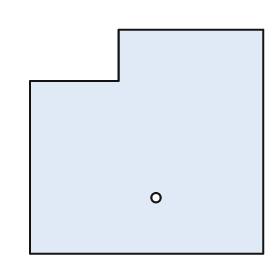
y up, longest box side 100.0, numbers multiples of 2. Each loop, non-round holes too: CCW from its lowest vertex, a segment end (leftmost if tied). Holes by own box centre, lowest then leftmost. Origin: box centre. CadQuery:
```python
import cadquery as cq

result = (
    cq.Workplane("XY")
    .moveTo(-50.0, -48.0)
    .lineTo(50.0, -48.0)
    .lineTo(50.0, 48.0)
    .lineTo(-12.0, 48.0)
    .lineTo(-12.0, 26.0)
    .lineTo(-50.0, 26.0)
    .close()
    .moveTo(4.0, -24.0)
    .circle(2.0)
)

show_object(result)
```